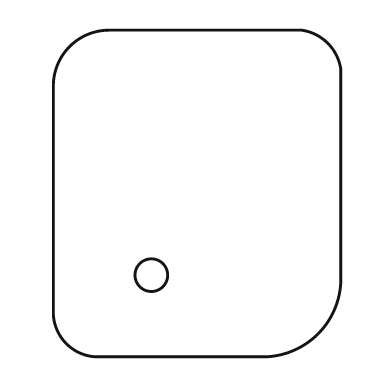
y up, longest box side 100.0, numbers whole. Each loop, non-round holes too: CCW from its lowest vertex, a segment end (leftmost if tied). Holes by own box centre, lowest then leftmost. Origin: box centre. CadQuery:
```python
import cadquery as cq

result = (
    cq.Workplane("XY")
    .moveTo(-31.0, -50.0)
    .lineTo(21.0, -50.0)
    .threePointArc((37.0, -43.0), (44.0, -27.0))
    .lineTo(44.0, 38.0)
    .threePointArc((40.0, 46.0), (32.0, 50.0))
    .lineTo(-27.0, 50.0)
    .threePointArc((-39.0, 45.0), (-44.0, 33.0))
    .lineTo(-44.0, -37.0)
    .threePointArc((-40.0, -46.0), (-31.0, -50.0))
    .close()
    .moveTo(-14.0, -25.0)
    .circle(5.0)
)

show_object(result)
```